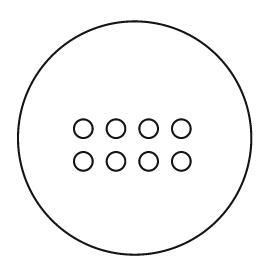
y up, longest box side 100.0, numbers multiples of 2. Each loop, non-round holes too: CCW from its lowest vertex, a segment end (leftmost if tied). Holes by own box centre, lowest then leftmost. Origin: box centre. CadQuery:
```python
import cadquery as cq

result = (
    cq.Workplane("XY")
    .moveTo(0.0, 0.0)
    .circle(50.0)
    .moveTo(-22.0, -10.0)
    .circle(4.0)
    .moveTo(-8.0, -10.0)
    .circle(4.0)
    .moveTo(6.0, -10.0)
    .circle(4.0)
    .moveTo(20.0, -10.0)
    .circle(4.0)
    .moveTo(-22.0, 4.0)
    .circle(4.0)
    .moveTo(-8.0, 4.0)
    .circle(4.0)
    .moveTo(6.0, 4.0)
    .circle(4.0)
    .moveTo(20.0, 4.0)
    .circle(4.0)
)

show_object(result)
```